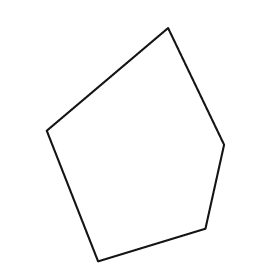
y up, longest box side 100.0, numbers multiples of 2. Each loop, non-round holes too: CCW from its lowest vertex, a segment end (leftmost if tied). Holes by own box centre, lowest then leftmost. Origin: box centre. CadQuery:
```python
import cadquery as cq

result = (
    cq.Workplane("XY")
    .moveTo(-16.0, -50.0)
    .lineTo(30.0, -36.0)
    .lineTo(38.0, 0.0)
    .lineTo(14.0, 50.0)
    .lineTo(-38.0, 6.0)
    .close()
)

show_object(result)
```